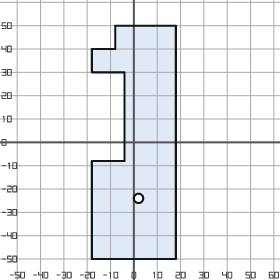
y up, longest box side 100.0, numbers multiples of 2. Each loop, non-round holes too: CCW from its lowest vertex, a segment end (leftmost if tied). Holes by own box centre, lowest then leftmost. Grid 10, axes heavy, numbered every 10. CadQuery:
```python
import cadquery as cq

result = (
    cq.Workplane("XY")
    .moveTo(-18.0, -50.0)
    .lineTo(18.0, -50.0)
    .lineTo(18.0, 50.0)
    .lineTo(-8.0, 50.0)
    .lineTo(-8.0, 40.0)
    .lineTo(-18.0, 40.0)
    .lineTo(-18.0, 30.0)
    .lineTo(-4.0, 30.0)
    .lineTo(-4.0, -8.0)
    .lineTo(-18.0, -8.0)
    .close()
    .moveTo(2.0, -24.0)
    .circle(2.0)
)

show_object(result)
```